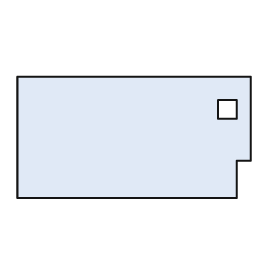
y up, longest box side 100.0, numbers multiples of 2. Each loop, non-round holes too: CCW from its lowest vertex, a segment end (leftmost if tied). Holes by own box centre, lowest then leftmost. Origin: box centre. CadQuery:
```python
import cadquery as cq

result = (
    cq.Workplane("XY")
    .moveTo(-50.0, -26.0)
    .lineTo(44.0, -26.0)
    .lineTo(44.0, -10.0)
    .lineTo(50.0, -10.0)
    .lineTo(50.0, 26.0)
    .lineTo(-50.0, 26.0)
    .close()
    .moveTo(36.0, 8.0)
    .lineTo(44.0, 8.0)
    .lineTo(44.0, 16.0)
    .lineTo(36.0, 16.0)
    .close()
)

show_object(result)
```